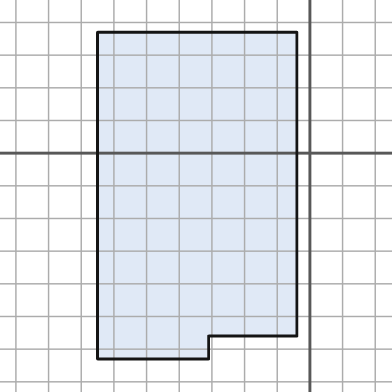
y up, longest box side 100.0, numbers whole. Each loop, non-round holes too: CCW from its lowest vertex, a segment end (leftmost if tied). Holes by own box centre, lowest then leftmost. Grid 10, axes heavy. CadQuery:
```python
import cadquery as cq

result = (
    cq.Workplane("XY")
    .moveTo(-65.0, -63.0)
    .lineTo(-31.0, -63.0)
    .lineTo(-31.0, -56.0)
    .lineTo(-4.0, -56.0)
    .lineTo(-4.0, 37.0)
    .lineTo(-65.0, 37.0)
    .close()
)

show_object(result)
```